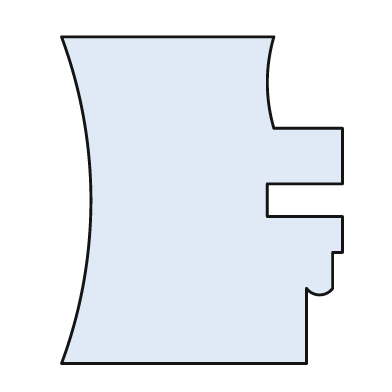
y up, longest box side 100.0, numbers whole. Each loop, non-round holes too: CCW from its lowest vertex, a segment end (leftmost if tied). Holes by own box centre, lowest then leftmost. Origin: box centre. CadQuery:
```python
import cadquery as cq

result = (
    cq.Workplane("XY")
    .moveTo(-43.0, -50.0)
    .lineTo(32.0, -50.0)
    .lineTo(32.0, -27.0)
    .threePointArc((36.0, -29.0), (40.0, -27.0))
    .lineTo(40.0, -16.0)
    .lineTo(43.0, -16.0)
    .lineTo(43.0, -5.0)
    .lineTo(20.0, -5.0)
    .lineTo(20.0, 5.0)
    .lineTo(43.0, 5.0)
    .lineTo(43.0, 22.0)
    .lineTo(22.0, 22.0)
    .threePointArc((20.0, 36.0), (22.0, 50.0))
    .lineTo(-43.0, 50.0)
    .threePointArc((-34.0, 0.0), (-43.0, -50.0))
    .close()
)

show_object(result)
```